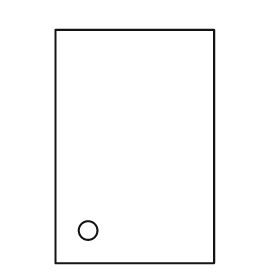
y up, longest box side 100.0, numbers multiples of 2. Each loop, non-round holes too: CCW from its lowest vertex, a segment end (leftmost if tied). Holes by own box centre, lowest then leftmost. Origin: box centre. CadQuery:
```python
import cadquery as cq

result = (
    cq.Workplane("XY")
    .moveTo(-34.0, -50.0)
    .lineTo(34.0, -50.0)
    .lineTo(34.0, 50.0)
    .lineTo(-34.0, 50.0)
    .close()
    .moveTo(-20.0, -36.0)
    .circle(4.0)
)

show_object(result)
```